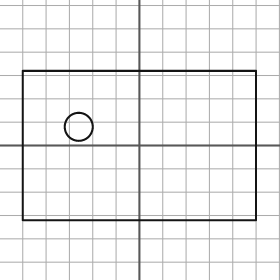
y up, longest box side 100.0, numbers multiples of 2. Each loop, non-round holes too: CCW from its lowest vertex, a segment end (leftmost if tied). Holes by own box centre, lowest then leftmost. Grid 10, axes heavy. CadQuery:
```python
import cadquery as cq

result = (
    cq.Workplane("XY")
    .moveTo(-50.0, -32.0)
    .lineTo(50.0, -32.0)
    .lineTo(50.0, 32.0)
    .lineTo(-50.0, 32.0)
    .close()
    .moveTo(-26.0, 8.0)
    .circle(6.0)
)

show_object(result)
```